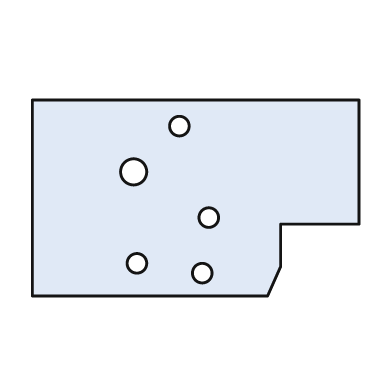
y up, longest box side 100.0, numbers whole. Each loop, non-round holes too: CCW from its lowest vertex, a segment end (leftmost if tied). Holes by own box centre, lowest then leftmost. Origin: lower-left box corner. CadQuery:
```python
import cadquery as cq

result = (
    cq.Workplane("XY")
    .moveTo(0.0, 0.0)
    .lineTo(72.0, 0.0)
    .lineTo(76.0, 9.0)
    .lineTo(76.0, 22.0)
    .lineTo(100.0, 22.0)
    .lineTo(100.0, 60.0)
    .lineTo(0.0, 60.0)
    .close()
    .moveTo(52.0, 7.0)
    .circle(3.0)
    .moveTo(32.0, 10.0)
    .circle(3.0)
    .moveTo(54.0, 24.0)
    .circle(3.0)
    .moveTo(31.0, 38.0)
    .circle(4.0)
    .moveTo(45.0, 52.0)
    .circle(3.0)
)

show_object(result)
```